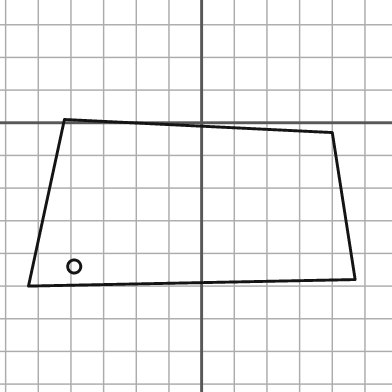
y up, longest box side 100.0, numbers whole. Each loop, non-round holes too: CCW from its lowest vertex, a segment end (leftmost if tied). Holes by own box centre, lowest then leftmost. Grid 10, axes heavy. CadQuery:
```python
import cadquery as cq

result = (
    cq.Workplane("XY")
    .moveTo(-53.0, -50.0)
    .lineTo(47.0, -48.0)
    .lineTo(40.0, -3.0)
    .lineTo(-42.0, 1.0)
    .close()
    .moveTo(-39.0, -44.0)
    .circle(2.0)
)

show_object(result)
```